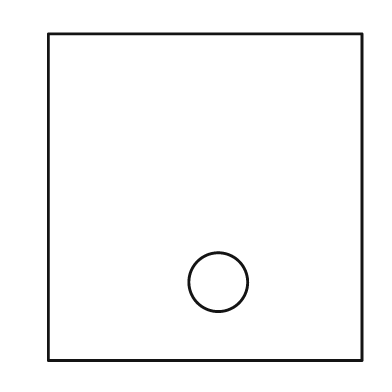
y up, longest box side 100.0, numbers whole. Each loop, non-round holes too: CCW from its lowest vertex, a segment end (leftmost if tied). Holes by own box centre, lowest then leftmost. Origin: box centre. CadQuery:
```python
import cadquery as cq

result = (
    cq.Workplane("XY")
    .moveTo(-48.0, -50.0)
    .lineTo(48.0, -50.0)
    .lineTo(48.0, 50.0)
    .lineTo(-48.0, 50.0)
    .close()
    .moveTo(4.0, -26.0)
    .circle(9.0)
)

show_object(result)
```